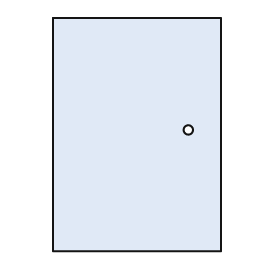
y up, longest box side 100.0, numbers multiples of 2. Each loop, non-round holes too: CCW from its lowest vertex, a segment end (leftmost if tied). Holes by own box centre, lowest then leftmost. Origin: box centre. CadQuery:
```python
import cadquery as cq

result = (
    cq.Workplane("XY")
    .moveTo(-36.0, -50.0)
    .lineTo(36.0, -50.0)
    .lineTo(36.0, 50.0)
    .lineTo(-36.0, 50.0)
    .close()
    .moveTo(22.0, 2.0)
    .circle(2.0)
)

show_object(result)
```